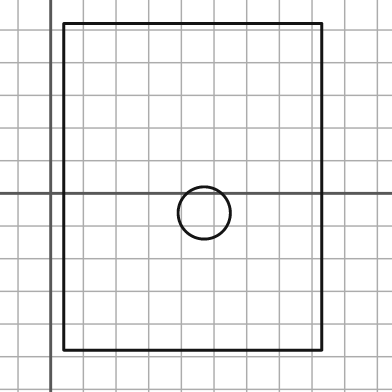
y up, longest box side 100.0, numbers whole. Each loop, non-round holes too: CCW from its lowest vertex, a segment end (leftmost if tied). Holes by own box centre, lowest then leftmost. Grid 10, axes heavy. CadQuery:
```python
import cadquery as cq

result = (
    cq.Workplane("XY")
    .moveTo(4.0, -48.0)
    .lineTo(83.0, -48.0)
    .lineTo(83.0, 52.0)
    .lineTo(4.0, 52.0)
    .close()
    .moveTo(47.0, -6.0)
    .circle(8.0)
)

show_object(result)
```